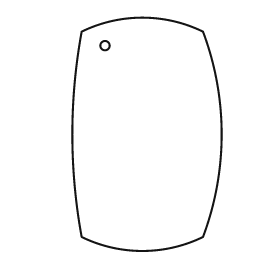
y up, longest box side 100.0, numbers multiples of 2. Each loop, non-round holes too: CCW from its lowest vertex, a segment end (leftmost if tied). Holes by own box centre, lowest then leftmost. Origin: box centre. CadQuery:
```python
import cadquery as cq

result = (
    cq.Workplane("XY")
    .moveTo(-28.0, -44.0)
    .threePointArc((-2.0, -50.0), (24.0, -44.0))
    .threePointArc((32.0, 0.0), (24.0, 44.0))
    .threePointArc((-2.0, 50.0), (-28.0, 44.0))
    .threePointArc((-32.0, 0.0), (-28.0, -44.0))
    .close()
    .moveTo(-18.0, 38.0)
    .circle(2.0)
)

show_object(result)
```